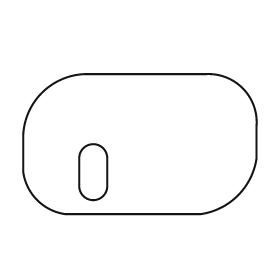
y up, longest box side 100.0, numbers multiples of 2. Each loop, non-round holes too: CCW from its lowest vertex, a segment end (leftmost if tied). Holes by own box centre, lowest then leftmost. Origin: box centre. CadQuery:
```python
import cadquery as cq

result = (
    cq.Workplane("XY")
    .moveTo(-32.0, -30.0)
    .lineTo(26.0, -30.0)
    .threePointArc((42.0, -22.0), (50.0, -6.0))
    .lineTo(50.0, 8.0)
    .threePointArc((44.0, 24.0), (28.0, 30.0))
    .lineTo(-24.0, 30.0)
    .threePointArc((-42.0, 22.0), (-50.0, 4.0))
    .lineTo(-50.0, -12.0)
    .threePointArc((-44.0, -24.0), (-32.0, -30.0))
    .close()
    .moveTo(-26.0, -18.0)
    .threePointArc((-20.0, -24.0), (-14.0, -18.0))
    .lineTo(-14.0, -6.0)
    .threePointArc((-20.0, 0.0), (-26.0, -6.0))
    .close()
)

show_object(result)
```